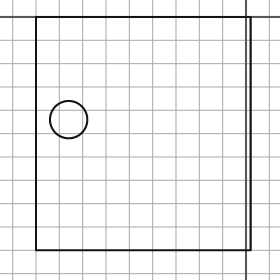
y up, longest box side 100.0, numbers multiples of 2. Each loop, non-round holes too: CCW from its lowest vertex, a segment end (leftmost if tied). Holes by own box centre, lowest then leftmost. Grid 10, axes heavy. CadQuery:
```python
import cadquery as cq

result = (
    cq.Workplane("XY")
    .moveTo(-90.0, -100.0)
    .lineTo(2.0, -100.0)
    .lineTo(2.0, 0.0)
    .lineTo(-90.0, 0.0)
    .close()
    .moveTo(-76.0, -44.0)
    .circle(8.0)
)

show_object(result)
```